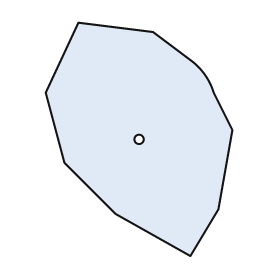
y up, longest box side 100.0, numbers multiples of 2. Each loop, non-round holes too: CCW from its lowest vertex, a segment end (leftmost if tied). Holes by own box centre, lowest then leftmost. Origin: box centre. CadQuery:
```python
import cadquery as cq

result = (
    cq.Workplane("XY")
    .moveTo(22.0, -50.0)
    .lineTo(34.0, -30.0)
    .lineTo(40.0, 4.0)
    .lineTo(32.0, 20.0)
    .threePointArc((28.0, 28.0), (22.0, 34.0))
    .lineTo(6.0, 46.0)
    .lineTo(-26.0, 50.0)
    .lineTo(-40.0, 20.0)
    .lineTo(-32.0, -10.0)
    .lineTo(-10.0, -32.0)
    .close()
    .moveTo(0.0, 0.0)
    .circle(2.0)
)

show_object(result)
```